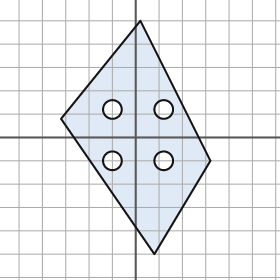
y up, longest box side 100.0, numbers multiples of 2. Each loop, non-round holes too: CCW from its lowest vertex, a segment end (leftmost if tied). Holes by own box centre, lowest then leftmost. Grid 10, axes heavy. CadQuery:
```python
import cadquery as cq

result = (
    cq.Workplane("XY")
    .moveTo(8.0, -50.0)
    .lineTo(32.0, -10.0)
    .lineTo(2.0, 50.0)
    .lineTo(-32.0, 8.0)
    .close()
    .moveTo(-10.0, -10.0)
    .circle(4.0)
    .moveTo(12.0, -10.0)
    .circle(4.0)
    .moveTo(-10.0, 12.0)
    .circle(4.0)
    .moveTo(12.0, 12.0)
    .circle(4.0)
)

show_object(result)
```